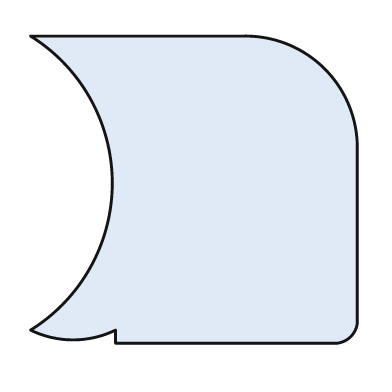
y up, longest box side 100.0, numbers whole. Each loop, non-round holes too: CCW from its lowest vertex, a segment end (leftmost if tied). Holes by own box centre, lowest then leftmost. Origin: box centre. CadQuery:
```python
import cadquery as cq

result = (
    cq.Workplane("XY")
    .moveTo(-24.0, -47.0)
    .lineTo(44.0, -47.0)
    .threePointArc((48.0, -45.0), (50.0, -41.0))
    .lineTo(50.0, 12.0)
    .threePointArc((40.0, 37.0), (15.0, 47.0))
    .lineTo(-50.0, 47.0)
    .threePointArc((-25.0, 2.0), (-50.0, -43.0))
    .threePointArc((-37.0, -46.0), (-24.0, -43.0))
    .close()
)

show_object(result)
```